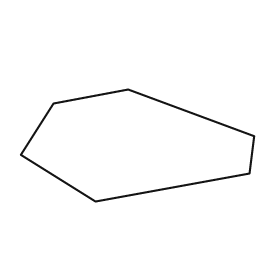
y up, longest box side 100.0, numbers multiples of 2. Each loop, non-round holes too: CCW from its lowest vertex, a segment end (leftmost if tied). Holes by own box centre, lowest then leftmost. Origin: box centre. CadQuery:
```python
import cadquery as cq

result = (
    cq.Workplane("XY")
    .moveTo(-18.0, -24.0)
    .lineTo(48.0, -12.0)
    .lineTo(50.0, 4.0)
    .lineTo(-4.0, 24.0)
    .lineTo(-36.0, 18.0)
    .lineTo(-50.0, -4.0)
    .close()
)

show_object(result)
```